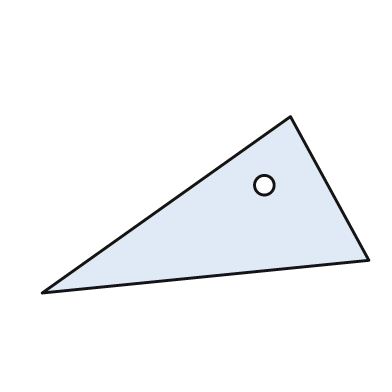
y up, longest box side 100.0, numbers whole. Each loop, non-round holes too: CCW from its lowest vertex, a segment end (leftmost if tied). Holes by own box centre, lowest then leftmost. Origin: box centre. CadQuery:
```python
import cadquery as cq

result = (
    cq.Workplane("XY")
    .moveTo(-50.0, -27.0)
    .lineTo(50.0, -17.0)
    .lineTo(26.0, 27.0)
    .close()
    .moveTo(18.0, 6.0)
    .circle(3.0)
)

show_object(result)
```